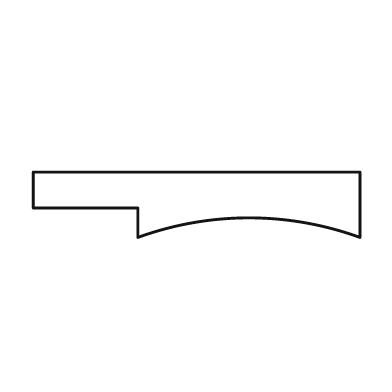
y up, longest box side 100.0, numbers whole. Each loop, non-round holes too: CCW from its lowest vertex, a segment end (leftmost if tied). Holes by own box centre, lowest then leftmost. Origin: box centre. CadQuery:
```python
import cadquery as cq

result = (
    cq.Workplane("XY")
    .moveTo(-18.0, -10.0)
    .threePointArc((16.0, -4.0), (50.0, -10.0))
    .lineTo(50.0, 10.0)
    .lineTo(-50.0, 10.0)
    .lineTo(-50.0, -1.0)
    .lineTo(-18.0, -1.0)
    .close()
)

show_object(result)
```